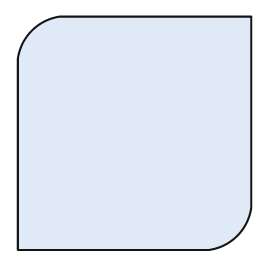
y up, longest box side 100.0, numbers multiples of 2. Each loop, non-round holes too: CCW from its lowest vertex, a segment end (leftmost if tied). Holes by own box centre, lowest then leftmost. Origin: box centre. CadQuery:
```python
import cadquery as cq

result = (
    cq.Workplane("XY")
    .moveTo(-50.0, -50.0)
    .lineTo(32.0, -50.0)
    .threePointArc((44.0, -44.0), (50.0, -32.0))
    .lineTo(50.0, 50.0)
    .lineTo(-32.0, 50.0)
    .threePointArc((-44.0, 44.0), (-50.0, 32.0))
    .close()
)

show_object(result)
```